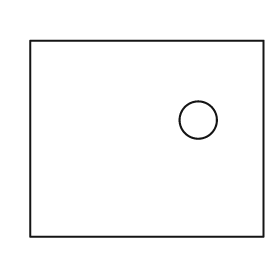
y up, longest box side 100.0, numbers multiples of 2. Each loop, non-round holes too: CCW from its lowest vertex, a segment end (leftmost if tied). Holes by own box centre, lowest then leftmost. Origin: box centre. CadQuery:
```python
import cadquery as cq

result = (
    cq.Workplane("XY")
    .moveTo(-50.0, -42.0)
    .lineTo(50.0, -42.0)
    .lineTo(50.0, 42.0)
    .lineTo(-50.0, 42.0)
    .close()
    .moveTo(22.0, 8.0)
    .circle(8.0)
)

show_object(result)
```